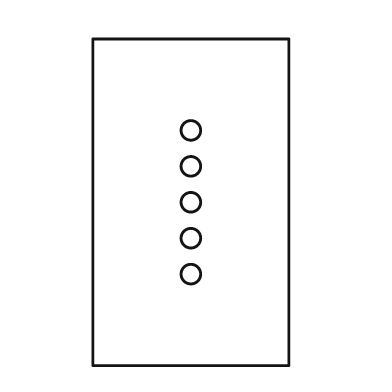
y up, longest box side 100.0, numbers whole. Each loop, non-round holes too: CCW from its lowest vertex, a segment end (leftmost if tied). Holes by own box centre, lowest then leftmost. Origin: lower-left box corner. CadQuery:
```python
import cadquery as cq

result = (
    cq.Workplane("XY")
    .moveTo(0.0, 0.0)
    .lineTo(60.0, 0.0)
    .lineTo(60.0, 100.0)
    .lineTo(0.0, 100.0)
    .close()
    .moveTo(30.0, 28.0)
    .circle(3.0)
    .moveTo(30.0, 39.0)
    .circle(3.0)
    .moveTo(30.0, 50.0)
    .circle(3.0)
    .moveTo(30.0, 61.0)
    .circle(3.0)
    .moveTo(30.0, 72.0)
    .circle(3.0)
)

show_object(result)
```